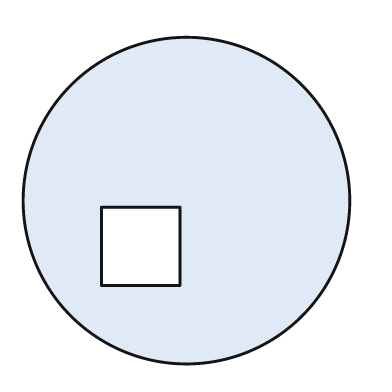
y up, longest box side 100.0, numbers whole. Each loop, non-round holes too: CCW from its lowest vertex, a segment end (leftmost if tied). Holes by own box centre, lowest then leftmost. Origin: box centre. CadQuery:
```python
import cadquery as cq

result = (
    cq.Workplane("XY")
    .moveTo(0.0, 0.0)
    .circle(50.0)
    .moveTo(-26.0, -26.0)
    .lineTo(-2.0, -26.0)
    .lineTo(-2.0, -2.0)
    .lineTo(-26.0, -2.0)
    .close()
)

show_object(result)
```